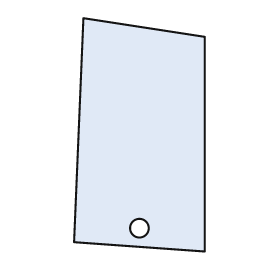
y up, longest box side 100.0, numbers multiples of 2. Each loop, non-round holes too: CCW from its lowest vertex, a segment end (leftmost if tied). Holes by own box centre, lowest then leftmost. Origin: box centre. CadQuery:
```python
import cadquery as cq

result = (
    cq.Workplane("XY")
    .moveTo(28.0, -50.0)
    .lineTo(28.0, 42.0)
    .lineTo(-24.0, 50.0)
    .lineTo(-28.0, -46.0)
    .close()
    .moveTo(0.0, -40.0)
    .circle(4.0)
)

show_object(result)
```